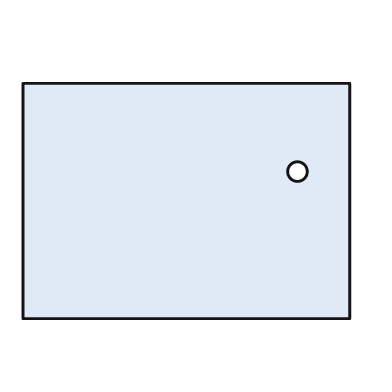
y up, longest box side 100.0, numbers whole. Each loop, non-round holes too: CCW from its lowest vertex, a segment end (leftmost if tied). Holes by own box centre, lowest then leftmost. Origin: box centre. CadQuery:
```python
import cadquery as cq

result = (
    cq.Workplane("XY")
    .moveTo(-50.0, -36.0)
    .lineTo(50.0, -36.0)
    .lineTo(50.0, 36.0)
    .lineTo(-50.0, 36.0)
    .close()
    .moveTo(34.0, 9.0)
    .circle(3.0)
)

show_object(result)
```